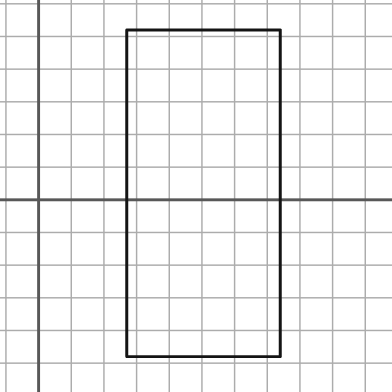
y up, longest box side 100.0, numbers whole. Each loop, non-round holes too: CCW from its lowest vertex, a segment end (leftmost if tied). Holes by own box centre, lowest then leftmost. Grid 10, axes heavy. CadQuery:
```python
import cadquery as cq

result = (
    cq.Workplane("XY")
    .moveTo(27.0, -48.0)
    .lineTo(74.0, -48.0)
    .lineTo(74.0, 52.0)
    .lineTo(27.0, 52.0)
    .close()
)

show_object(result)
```